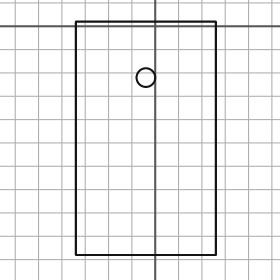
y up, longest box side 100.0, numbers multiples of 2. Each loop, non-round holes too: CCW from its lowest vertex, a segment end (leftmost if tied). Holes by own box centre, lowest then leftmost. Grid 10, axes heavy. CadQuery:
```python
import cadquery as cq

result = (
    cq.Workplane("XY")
    .moveTo(-34.0, -98.0)
    .lineTo(26.0, -98.0)
    .lineTo(26.0, 2.0)
    .lineTo(-34.0, 2.0)
    .close()
    .moveTo(-4.0, -22.0)
    .circle(4.0)
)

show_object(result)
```